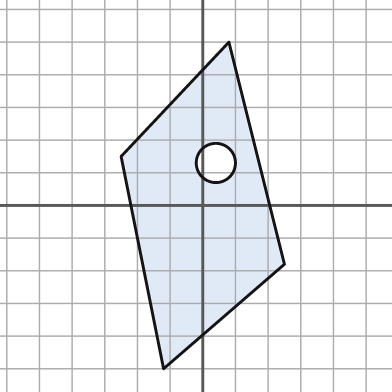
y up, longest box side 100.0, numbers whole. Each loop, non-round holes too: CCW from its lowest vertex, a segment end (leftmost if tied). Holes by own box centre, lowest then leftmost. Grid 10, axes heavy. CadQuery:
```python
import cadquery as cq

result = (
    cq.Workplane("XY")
    .moveTo(-12.0, -50.0)
    .lineTo(25.0, -18.0)
    .lineTo(8.0, 50.0)
    .lineTo(-25.0, 15.0)
    .close()
    .moveTo(4.0, 13.0)
    .circle(6.0)
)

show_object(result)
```